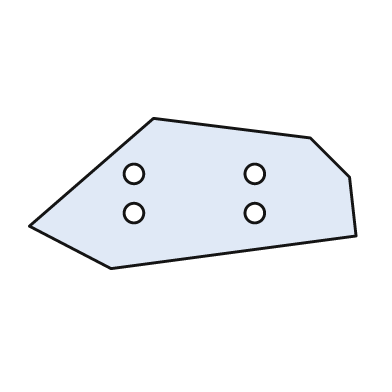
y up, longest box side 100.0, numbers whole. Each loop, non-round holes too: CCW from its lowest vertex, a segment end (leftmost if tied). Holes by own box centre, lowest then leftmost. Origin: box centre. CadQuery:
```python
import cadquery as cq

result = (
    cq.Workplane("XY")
    .moveTo(-25.0, -23.0)
    .lineTo(50.0, -13.0)
    .lineTo(48.0, 5.0)
    .lineTo(36.0, 17.0)
    .lineTo(-12.0, 23.0)
    .lineTo(-50.0, -10.0)
    .close()
    .moveTo(-18.0, -6.0)
    .circle(3.0)
    .moveTo(19.0, -6.0)
    .circle(3.0)
    .moveTo(-18.0, 6.0)
    .circle(3.0)
    .moveTo(19.0, 6.0)
    .circle(3.0)
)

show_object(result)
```